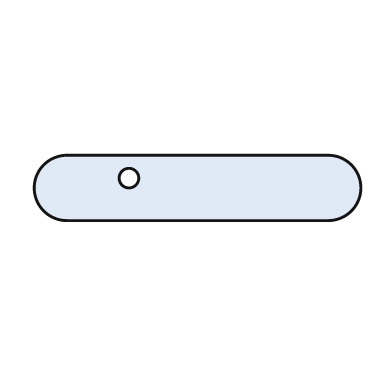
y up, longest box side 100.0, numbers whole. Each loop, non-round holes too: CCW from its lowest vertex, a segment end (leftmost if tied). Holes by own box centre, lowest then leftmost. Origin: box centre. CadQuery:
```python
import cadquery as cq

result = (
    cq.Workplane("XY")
    .moveTo(-40.0, -10.0)
    .lineTo(40.0, -10.0)
    .threePointArc((50.0, 0.0), (40.0, 10.0))
    .lineTo(-40.0, 10.0)
    .threePointArc((-50.0, 0.0), (-40.0, -10.0))
    .close()
    .moveTo(-21.0, 3.0)
    .circle(3.0)
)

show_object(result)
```